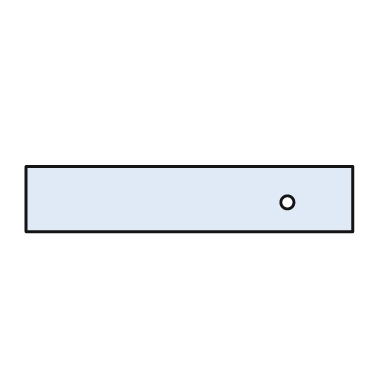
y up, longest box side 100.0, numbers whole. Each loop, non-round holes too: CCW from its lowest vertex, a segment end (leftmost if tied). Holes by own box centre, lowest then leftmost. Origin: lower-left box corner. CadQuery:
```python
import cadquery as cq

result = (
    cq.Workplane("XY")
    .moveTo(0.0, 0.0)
    .lineTo(100.0, 0.0)
    .lineTo(100.0, 20.0)
    .lineTo(0.0, 20.0)
    .close()
    .moveTo(80.0, 9.0)
    .circle(2.0)
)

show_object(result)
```